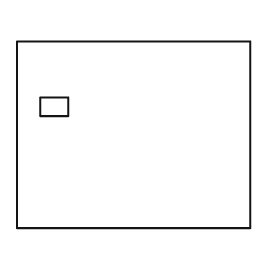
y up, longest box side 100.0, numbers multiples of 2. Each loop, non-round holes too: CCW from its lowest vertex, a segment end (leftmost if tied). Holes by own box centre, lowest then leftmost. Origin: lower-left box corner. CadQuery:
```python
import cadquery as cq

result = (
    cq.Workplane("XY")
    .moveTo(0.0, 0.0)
    .lineTo(100.0, 0.0)
    .lineTo(100.0, 80.0)
    .lineTo(0.0, 80.0)
    .close()
    .moveTo(10.0, 48.0)
    .lineTo(22.0, 48.0)
    .lineTo(22.0, 56.0)
    .lineTo(10.0, 56.0)
    .close()
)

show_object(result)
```